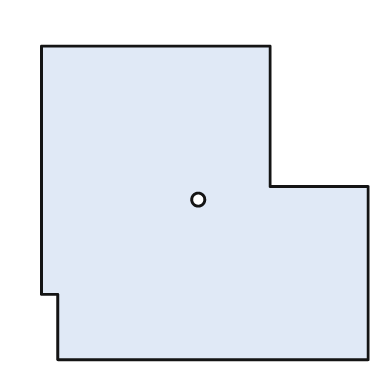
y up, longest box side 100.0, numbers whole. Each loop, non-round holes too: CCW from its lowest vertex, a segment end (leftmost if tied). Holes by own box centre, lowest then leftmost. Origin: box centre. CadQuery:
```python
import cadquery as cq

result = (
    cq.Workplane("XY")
    .moveTo(-45.0, -48.0)
    .lineTo(50.0, -48.0)
    .lineTo(50.0, 5.0)
    .lineTo(20.0, 5.0)
    .lineTo(20.0, 48.0)
    .lineTo(-50.0, 48.0)
    .lineTo(-50.0, -28.0)
    .lineTo(-45.0, -28.0)
    .close()
    .moveTo(-2.0, 1.0)
    .circle(2.0)
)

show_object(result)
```